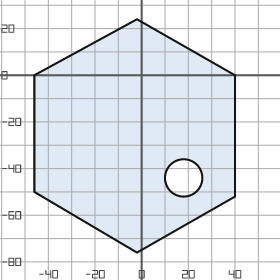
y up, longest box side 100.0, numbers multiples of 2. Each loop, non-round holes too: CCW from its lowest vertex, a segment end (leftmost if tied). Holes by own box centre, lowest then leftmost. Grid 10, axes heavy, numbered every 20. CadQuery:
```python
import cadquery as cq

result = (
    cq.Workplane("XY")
    .moveTo(-2.0, -76.0)
    .lineTo(40.0, -52.0)
    .lineTo(40.0, 0.0)
    .lineTo(-2.0, 24.0)
    .lineTo(-46.0, 0.0)
    .lineTo(-46.0, -50.0)
    .close()
    .moveTo(18.0, -44.0)
    .circle(8.0)
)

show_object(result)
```